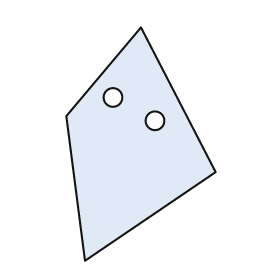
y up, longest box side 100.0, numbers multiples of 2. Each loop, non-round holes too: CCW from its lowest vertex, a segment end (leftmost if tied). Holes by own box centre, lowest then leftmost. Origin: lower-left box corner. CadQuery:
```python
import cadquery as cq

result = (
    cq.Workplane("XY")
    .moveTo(8.0, 0.0)
    .lineTo(64.0, 38.0)
    .lineTo(32.0, 100.0)
    .lineTo(0.0, 62.0)
    .close()
    .moveTo(38.0, 60.0)
    .circle(4.0)
    .moveTo(20.0, 70.0)
    .circle(4.0)
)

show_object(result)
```